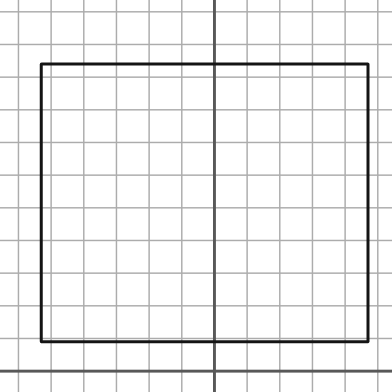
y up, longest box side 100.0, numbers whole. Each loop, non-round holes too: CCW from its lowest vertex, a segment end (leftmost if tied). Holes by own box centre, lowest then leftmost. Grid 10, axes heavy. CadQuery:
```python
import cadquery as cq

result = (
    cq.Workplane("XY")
    .moveTo(-53.0, 9.0)
    .lineTo(47.0, 9.0)
    .lineTo(47.0, 94.0)
    .lineTo(-53.0, 94.0)
    .close()
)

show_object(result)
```